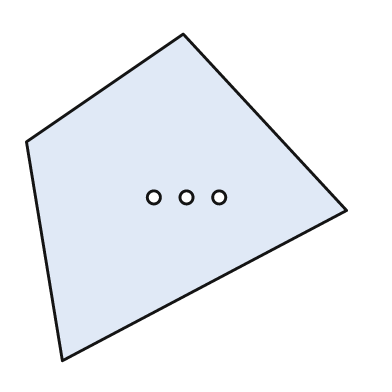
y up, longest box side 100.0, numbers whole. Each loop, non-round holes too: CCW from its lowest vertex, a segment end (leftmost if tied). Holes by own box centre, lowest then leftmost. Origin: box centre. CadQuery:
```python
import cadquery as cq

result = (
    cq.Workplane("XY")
    .moveTo(-38.0, -50.0)
    .lineTo(49.0, -4.0)
    .lineTo(-1.0, 50.0)
    .lineTo(-49.0, 17.0)
    .close()
    .moveTo(-10.0, 0.0)
    .circle(2.0)
    .moveTo(0.0, 0.0)
    .circle(2.0)
    .moveTo(10.0, 0.0)
    .circle(2.0)
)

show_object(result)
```